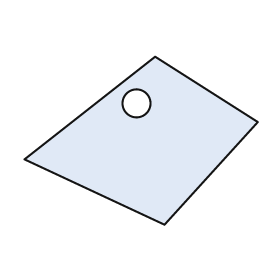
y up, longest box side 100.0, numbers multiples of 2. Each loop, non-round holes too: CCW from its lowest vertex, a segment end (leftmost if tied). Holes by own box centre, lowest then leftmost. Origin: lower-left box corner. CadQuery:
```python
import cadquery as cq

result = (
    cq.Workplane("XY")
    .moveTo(60.0, 0.0)
    .lineTo(100.0, 44.0)
    .lineTo(56.0, 72.0)
    .lineTo(0.0, 28.0)
    .close()
    .moveTo(48.0, 52.0)
    .circle(6.0)
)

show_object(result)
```